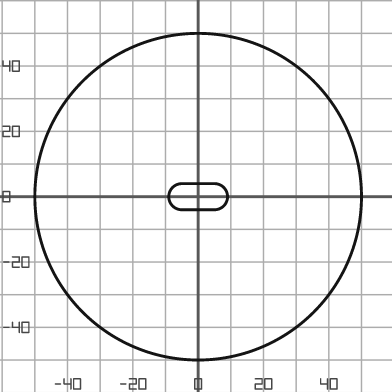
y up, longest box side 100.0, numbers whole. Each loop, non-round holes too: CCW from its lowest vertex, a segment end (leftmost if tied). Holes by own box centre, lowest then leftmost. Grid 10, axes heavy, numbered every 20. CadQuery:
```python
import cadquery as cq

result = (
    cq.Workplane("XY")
    .moveTo(0.0, 0.0)
    .circle(50.0)
    .moveTo(-5.0, -4.0)
    .lineTo(5.0, -4.0)
    .threePointArc((9.0, 0.0), (5.0, 4.0))
    .lineTo(-5.0, 4.0)
    .threePointArc((-9.0, 0.0), (-5.0, -4.0))
    .close()
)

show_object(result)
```